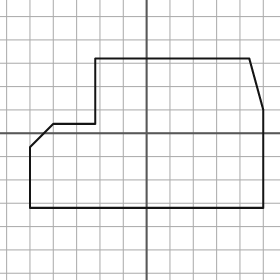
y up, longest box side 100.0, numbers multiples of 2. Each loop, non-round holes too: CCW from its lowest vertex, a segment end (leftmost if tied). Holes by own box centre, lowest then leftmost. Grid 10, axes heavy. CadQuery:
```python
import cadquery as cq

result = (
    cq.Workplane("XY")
    .moveTo(-50.0, -32.0)
    .lineTo(50.0, -32.0)
    .lineTo(50.0, 10.0)
    .lineTo(44.0, 32.0)
    .lineTo(-22.0, 32.0)
    .lineTo(-22.0, 4.0)
    .lineTo(-40.0, 4.0)
    .lineTo(-50.0, -6.0)
    .close()
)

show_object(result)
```